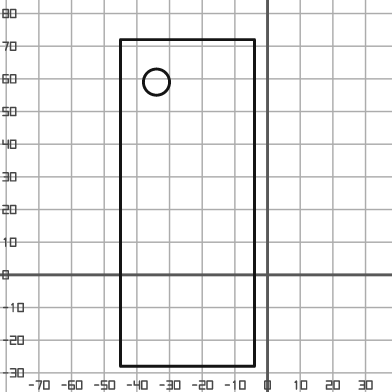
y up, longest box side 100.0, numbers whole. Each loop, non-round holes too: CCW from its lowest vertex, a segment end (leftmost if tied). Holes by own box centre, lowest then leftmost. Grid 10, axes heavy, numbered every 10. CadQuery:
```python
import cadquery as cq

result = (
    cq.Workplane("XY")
    .moveTo(-45.0, -28.0)
    .lineTo(-4.0, -28.0)
    .lineTo(-4.0, 72.0)
    .lineTo(-45.0, 72.0)
    .close()
    .moveTo(-34.0, 59.0)
    .circle(4.0)
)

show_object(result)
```